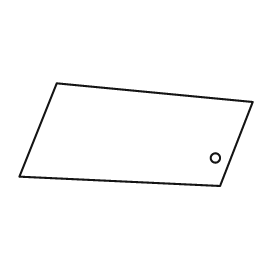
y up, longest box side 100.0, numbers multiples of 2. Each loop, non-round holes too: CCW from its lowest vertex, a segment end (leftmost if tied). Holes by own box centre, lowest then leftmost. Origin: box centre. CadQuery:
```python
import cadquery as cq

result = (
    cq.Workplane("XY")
    .moveTo(36.0, -22.0)
    .lineTo(50.0, 14.0)
    .lineTo(-34.0, 22.0)
    .lineTo(-50.0, -18.0)
    .close()
    .moveTo(34.0, -10.0)
    .circle(2.0)
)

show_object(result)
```